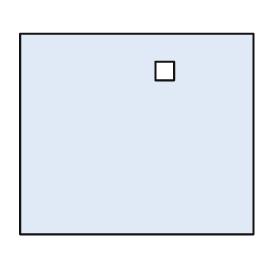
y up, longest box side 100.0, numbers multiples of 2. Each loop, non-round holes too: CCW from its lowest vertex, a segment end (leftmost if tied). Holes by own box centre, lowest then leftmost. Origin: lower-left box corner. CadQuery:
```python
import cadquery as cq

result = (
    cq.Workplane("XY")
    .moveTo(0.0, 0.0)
    .lineTo(100.0, 0.0)
    .lineTo(100.0, 86.0)
    .lineTo(0.0, 86.0)
    .close()
    .moveTo(58.0, 66.0)
    .lineTo(66.0, 66.0)
    .lineTo(66.0, 74.0)
    .lineTo(58.0, 74.0)
    .close()
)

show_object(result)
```